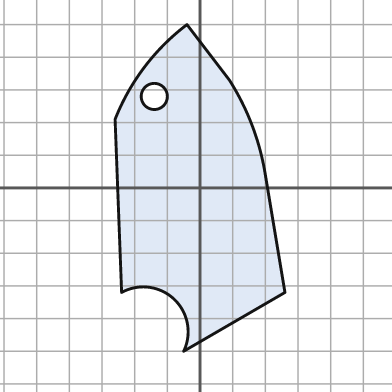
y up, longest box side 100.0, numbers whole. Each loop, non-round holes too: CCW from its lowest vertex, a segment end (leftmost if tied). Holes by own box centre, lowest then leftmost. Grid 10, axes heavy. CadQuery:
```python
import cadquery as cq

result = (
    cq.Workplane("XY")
    .moveTo(-5.0, -50.0)
    .lineTo(26.0, -32.0)
    .lineTo(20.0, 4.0)
    .threePointArc((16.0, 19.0), (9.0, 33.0))
    .lineTo(-4.0, 50.0)
    .threePointArc((-17.0, 37.0), (-26.0, 21.0))
    .lineTo(-24.0, -32.0)
    .threePointArc((-8.0, -34.0), (-5.0, -50.0))
    .close()
    .moveTo(-14.0, 28.0)
    .circle(4.0)
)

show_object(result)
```